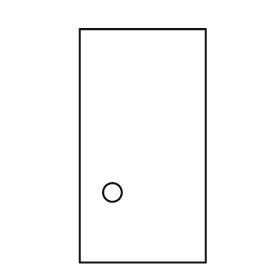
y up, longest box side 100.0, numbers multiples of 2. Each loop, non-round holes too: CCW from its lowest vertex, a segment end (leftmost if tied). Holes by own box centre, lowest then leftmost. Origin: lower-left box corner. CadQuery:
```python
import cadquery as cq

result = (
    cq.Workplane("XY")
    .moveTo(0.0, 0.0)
    .lineTo(54.0, 0.0)
    .lineTo(54.0, 100.0)
    .lineTo(0.0, 100.0)
    .close()
    .moveTo(14.0, 30.0)
    .circle(4.0)
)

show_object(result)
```